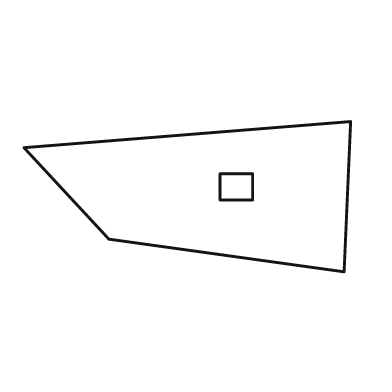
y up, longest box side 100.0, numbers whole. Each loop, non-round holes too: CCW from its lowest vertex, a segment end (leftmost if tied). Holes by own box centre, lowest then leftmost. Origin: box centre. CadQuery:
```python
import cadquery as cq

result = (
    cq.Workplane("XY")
    .moveTo(48.0, -23.0)
    .lineTo(50.0, 23.0)
    .lineTo(-50.0, 15.0)
    .lineTo(-24.0, -13.0)
    .close()
    .moveTo(10.0, -1.0)
    .lineTo(20.0, -1.0)
    .lineTo(20.0, 7.0)
    .lineTo(10.0, 7.0)
    .close()
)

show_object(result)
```